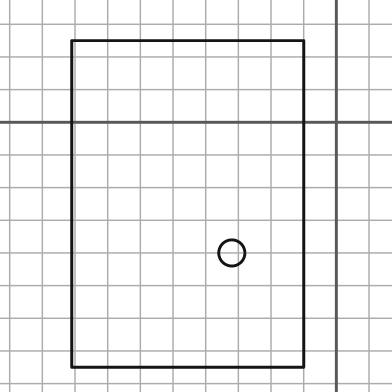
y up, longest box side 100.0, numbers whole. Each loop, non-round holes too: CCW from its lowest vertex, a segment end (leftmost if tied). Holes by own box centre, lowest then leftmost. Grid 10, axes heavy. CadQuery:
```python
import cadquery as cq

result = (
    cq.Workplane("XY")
    .moveTo(-81.0, -75.0)
    .lineTo(-10.0, -75.0)
    .lineTo(-10.0, 25.0)
    .lineTo(-81.0, 25.0)
    .close()
    .moveTo(-32.0, -40.0)
    .circle(4.0)
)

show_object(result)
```